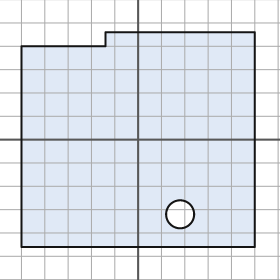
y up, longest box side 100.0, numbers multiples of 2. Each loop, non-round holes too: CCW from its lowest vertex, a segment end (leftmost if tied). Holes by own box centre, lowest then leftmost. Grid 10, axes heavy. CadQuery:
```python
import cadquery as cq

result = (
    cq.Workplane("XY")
    .moveTo(-50.0, -46.0)
    .lineTo(50.0, -46.0)
    .lineTo(50.0, 46.0)
    .lineTo(-14.0, 46.0)
    .lineTo(-14.0, 40.0)
    .lineTo(-50.0, 40.0)
    .close()
    .moveTo(18.0, -32.0)
    .circle(6.0)
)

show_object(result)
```